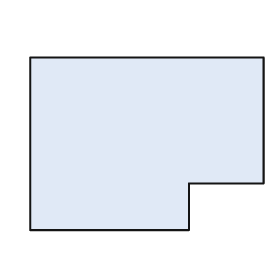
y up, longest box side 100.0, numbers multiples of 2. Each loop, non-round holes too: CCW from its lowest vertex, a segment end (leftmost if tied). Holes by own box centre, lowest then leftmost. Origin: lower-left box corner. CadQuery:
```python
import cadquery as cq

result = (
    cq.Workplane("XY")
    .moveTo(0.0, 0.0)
    .lineTo(68.0, 0.0)
    .lineTo(68.0, 20.0)
    .lineTo(100.0, 20.0)
    .lineTo(100.0, 74.0)
    .lineTo(0.0, 74.0)
    .close()
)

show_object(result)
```